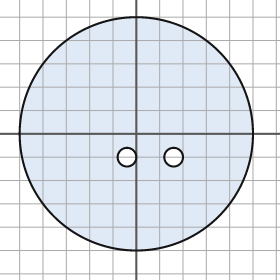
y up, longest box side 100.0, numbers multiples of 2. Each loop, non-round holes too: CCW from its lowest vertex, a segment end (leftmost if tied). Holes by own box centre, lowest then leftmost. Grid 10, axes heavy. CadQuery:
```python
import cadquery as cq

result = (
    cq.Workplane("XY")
    .moveTo(0.0, 0.0)
    .circle(50.0)
    .moveTo(-4.0, -10.0)
    .circle(4.0)
    .moveTo(16.0, -10.0)
    .circle(4.0)
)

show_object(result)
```